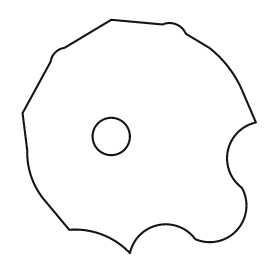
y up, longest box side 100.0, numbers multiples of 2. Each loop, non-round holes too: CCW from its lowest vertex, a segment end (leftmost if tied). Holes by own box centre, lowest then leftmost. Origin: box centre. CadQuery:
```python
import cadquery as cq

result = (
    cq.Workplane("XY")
    .moveTo(-4.0, -50.0)
    .threePointArc((8.0, -38.0), (24.0, -44.0))
    .threePointArc((42.0, -40.0), (44.0, -22.0))
    .threePointArc((38.0, -6.0), (50.0, 6.0))
    .lineTo(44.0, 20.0)
    .threePointArc((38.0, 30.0), (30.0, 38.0))
    .lineTo(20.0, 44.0)
    .threePointArc((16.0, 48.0), (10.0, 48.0))
    .lineTo(-12.0, 50.0)
    .lineTo(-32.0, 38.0)
    .threePointArc((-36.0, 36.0), (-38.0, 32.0))
    .lineTo(-50.0, 10.0)
    .lineTo(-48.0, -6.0)
    .threePointArc((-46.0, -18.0), (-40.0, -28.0))
    .lineTo(-30.0, -40.0)
    .threePointArc((-16.0, -42.0), (-4.0, -50.0))
    .close()
    .moveTo(-12.0, 0.0)
    .circle(8.0)
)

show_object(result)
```